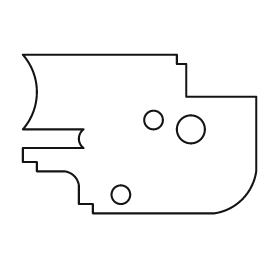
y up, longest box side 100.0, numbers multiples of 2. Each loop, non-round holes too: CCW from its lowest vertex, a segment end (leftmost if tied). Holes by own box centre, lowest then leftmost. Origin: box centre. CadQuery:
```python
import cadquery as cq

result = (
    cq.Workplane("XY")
    .moveTo(-20.0, -34.0)
    .lineTo(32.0, -34.0)
    .threePointArc((44.0, -28.0), (50.0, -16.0))
    .lineTo(50.0, 16.0)
    .lineTo(20.0, 16.0)
    .lineTo(20.0, 30.0)
    .lineTo(16.0, 30.0)
    .lineTo(16.0, 34.0)
    .lineTo(-50.0, 34.0)
    .threePointArc((-44.0, 18.0), (-50.0, 2.0))
    .lineTo(-24.0, 2.0)
    .threePointArc((-26.0, -2.0), (-24.0, -6.0))
    .lineTo(-50.0, -6.0)
    .lineTo(-50.0, -12.0)
    .lineTo(-44.0, -12.0)
    .lineTo(-44.0, -16.0)
    .lineTo(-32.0, -16.0)
    .threePointArc((-28.0, -18.0), (-26.0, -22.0))
    .lineTo(-26.0, -30.0)
    .lineTo(-20.0, -30.0)
    .close()
    .moveTo(-8.0, -26.0)
    .circle(4.0)
    .moveTo(22.0, 2.0)
    .circle(6.0)
    .moveTo(6.0, 6.0)
    .circle(4.0)
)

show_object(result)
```